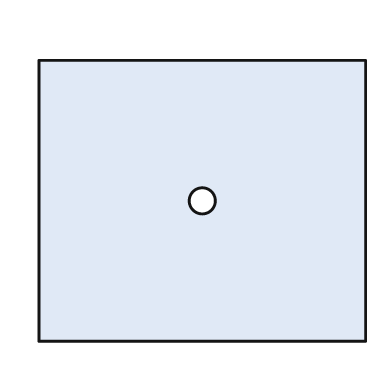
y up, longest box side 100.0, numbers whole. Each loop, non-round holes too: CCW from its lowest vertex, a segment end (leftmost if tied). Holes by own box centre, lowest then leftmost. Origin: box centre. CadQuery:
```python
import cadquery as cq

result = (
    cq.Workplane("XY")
    .moveTo(-50.0, -43.0)
    .lineTo(50.0, -43.0)
    .lineTo(50.0, 43.0)
    .lineTo(-50.0, 43.0)
    .close()
    .moveTo(0.0, 0.0)
    .circle(4.0)
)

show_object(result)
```